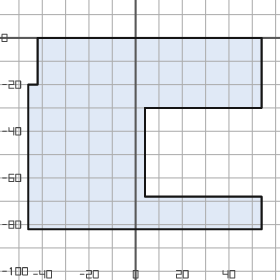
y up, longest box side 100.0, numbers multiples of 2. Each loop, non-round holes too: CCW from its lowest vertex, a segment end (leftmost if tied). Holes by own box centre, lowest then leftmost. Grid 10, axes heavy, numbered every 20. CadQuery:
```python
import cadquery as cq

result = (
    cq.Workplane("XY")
    .moveTo(-46.0, -82.0)
    .lineTo(54.0, -82.0)
    .lineTo(54.0, -68.0)
    .lineTo(4.0, -68.0)
    .lineTo(4.0, -30.0)
    .lineTo(54.0, -30.0)
    .lineTo(54.0, 0.0)
    .lineTo(-42.0, 0.0)
    .lineTo(-42.0, -20.0)
    .lineTo(-46.0, -20.0)
    .close()
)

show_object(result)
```